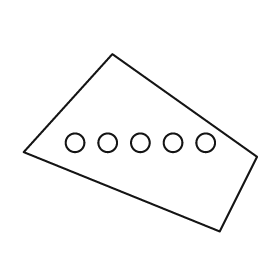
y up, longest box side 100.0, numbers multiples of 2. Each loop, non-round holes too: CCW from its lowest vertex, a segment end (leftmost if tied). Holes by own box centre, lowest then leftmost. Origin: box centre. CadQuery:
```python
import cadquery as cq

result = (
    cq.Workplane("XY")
    .moveTo(34.0, -38.0)
    .lineTo(50.0, -6.0)
    .lineTo(-12.0, 38.0)
    .lineTo(-50.0, -4.0)
    .close()
    .moveTo(-28.0, 0.0)
    .circle(4.0)
    .moveTo(-14.0, 0.0)
    .circle(4.0)
    .moveTo(0.0, 0.0)
    .circle(4.0)
    .moveTo(14.0, 0.0)
    .circle(4.0)
    .moveTo(28.0, 0.0)
    .circle(4.0)
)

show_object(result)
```